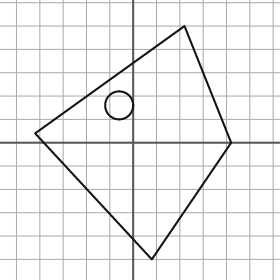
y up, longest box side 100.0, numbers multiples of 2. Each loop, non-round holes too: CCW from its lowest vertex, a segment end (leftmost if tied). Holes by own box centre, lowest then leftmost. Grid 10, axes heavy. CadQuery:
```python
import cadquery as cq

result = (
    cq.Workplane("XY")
    .moveTo(8.0, -50.0)
    .lineTo(42.0, 0.0)
    .lineTo(22.0, 50.0)
    .lineTo(-42.0, 4.0)
    .close()
    .moveTo(-6.0, 16.0)
    .circle(6.0)
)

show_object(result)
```